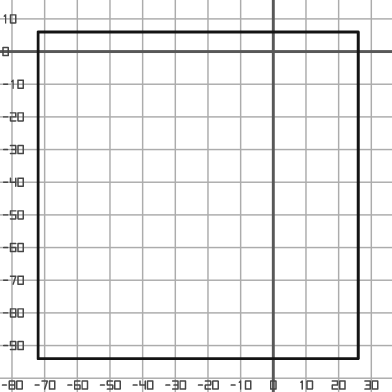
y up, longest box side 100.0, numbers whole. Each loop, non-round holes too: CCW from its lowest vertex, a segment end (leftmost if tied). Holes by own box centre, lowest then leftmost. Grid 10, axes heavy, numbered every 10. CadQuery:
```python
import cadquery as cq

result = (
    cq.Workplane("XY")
    .moveTo(-72.0, -94.0)
    .lineTo(26.0, -94.0)
    .lineTo(26.0, 6.0)
    .lineTo(-72.0, 6.0)
    .close()
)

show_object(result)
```